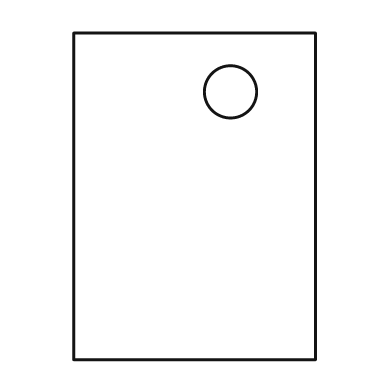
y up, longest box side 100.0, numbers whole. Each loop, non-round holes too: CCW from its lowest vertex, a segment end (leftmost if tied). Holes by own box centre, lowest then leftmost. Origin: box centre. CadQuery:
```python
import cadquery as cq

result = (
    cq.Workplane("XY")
    .moveTo(-37.0, -50.0)
    .lineTo(37.0, -50.0)
    .lineTo(37.0, 50.0)
    .lineTo(-37.0, 50.0)
    .close()
    .moveTo(11.0, 32.0)
    .circle(8.0)
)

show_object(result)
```